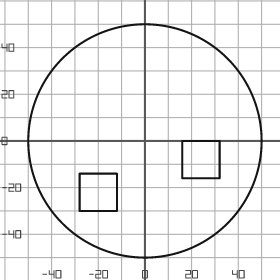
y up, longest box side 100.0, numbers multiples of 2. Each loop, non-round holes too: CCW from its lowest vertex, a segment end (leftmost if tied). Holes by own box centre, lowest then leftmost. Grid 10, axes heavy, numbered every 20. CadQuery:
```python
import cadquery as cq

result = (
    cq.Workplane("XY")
    .moveTo(0.0, 0.0)
    .circle(50.0)
    .moveTo(-28.0, -30.0)
    .lineTo(-12.0, -30.0)
    .lineTo(-12.0, -14.0)
    .lineTo(-28.0, -14.0)
    .close()
    .moveTo(16.0, -16.0)
    .lineTo(32.0, -16.0)
    .lineTo(32.0, 0.0)
    .lineTo(16.0, 0.0)
    .close()
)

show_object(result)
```